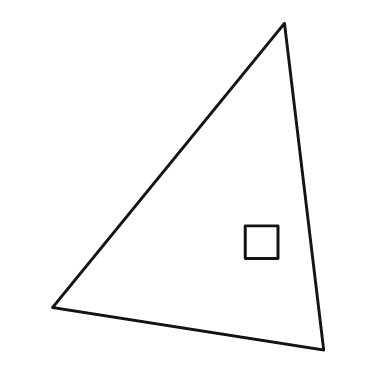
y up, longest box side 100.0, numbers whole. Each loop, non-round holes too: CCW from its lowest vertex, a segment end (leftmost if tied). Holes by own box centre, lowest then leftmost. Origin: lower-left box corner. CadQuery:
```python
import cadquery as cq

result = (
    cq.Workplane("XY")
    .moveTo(83.0, 0.0)
    .lineTo(71.0, 100.0)
    .lineTo(0.0, 13.0)
    .close()
    .moveTo(59.0, 28.0)
    .lineTo(69.0, 28.0)
    .lineTo(69.0, 38.0)
    .lineTo(59.0, 38.0)
    .close()
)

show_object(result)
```